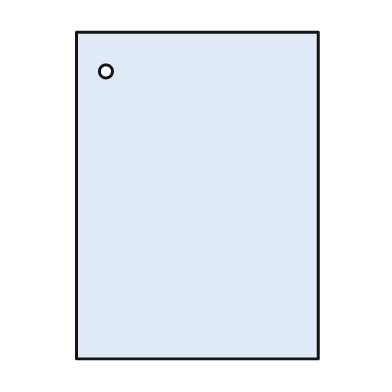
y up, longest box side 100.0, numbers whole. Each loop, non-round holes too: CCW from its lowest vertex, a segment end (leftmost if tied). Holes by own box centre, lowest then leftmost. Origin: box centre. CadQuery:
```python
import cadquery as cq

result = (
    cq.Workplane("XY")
    .moveTo(-37.0, -50.0)
    .lineTo(37.0, -50.0)
    .lineTo(37.0, 50.0)
    .lineTo(-37.0, 50.0)
    .close()
    .moveTo(-28.0, 38.0)
    .circle(2.0)
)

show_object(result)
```